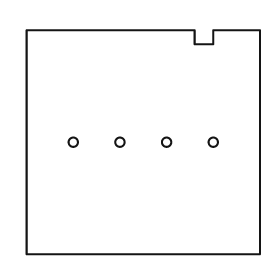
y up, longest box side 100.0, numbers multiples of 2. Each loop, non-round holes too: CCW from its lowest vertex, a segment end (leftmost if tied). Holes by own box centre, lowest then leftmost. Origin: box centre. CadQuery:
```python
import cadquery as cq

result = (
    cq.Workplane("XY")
    .moveTo(-50.0, -48.0)
    .lineTo(50.0, -48.0)
    .lineTo(50.0, 48.0)
    .lineTo(30.0, 48.0)
    .lineTo(30.0, 42.0)
    .lineTo(22.0, 42.0)
    .lineTo(22.0, 48.0)
    .lineTo(-50.0, 48.0)
    .close()
    .moveTo(-30.0, 0.0)
    .circle(2.0)
    .moveTo(-10.0, 0.0)
    .circle(2.0)
    .moveTo(10.0, 0.0)
    .circle(2.0)
    .moveTo(30.0, 0.0)
    .circle(2.0)
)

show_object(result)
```